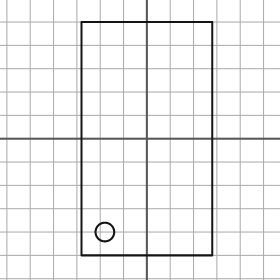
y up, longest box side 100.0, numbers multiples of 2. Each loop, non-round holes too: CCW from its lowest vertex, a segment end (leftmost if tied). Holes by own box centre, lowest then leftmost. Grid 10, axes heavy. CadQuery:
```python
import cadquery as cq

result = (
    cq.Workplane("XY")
    .moveTo(-28.0, -50.0)
    .lineTo(28.0, -50.0)
    .lineTo(28.0, 50.0)
    .lineTo(-28.0, 50.0)
    .close()
    .moveTo(-18.0, -40.0)
    .circle(4.0)
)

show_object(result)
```